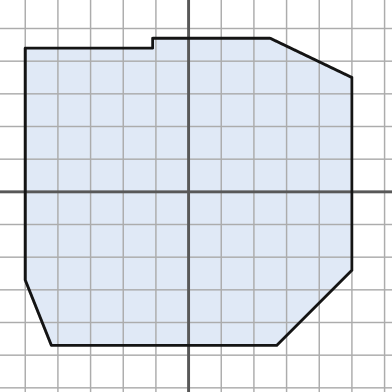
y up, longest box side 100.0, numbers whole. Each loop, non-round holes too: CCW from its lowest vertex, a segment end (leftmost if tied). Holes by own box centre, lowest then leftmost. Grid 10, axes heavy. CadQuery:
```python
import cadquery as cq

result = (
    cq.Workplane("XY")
    .moveTo(-42.0, -47.0)
    .lineTo(27.0, -47.0)
    .lineTo(50.0, -24.0)
    .lineTo(50.0, 35.0)
    .lineTo(25.0, 47.0)
    .lineTo(-11.0, 47.0)
    .lineTo(-11.0, 44.0)
    .lineTo(-50.0, 44.0)
    .lineTo(-50.0, -27.0)
    .close()
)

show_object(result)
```